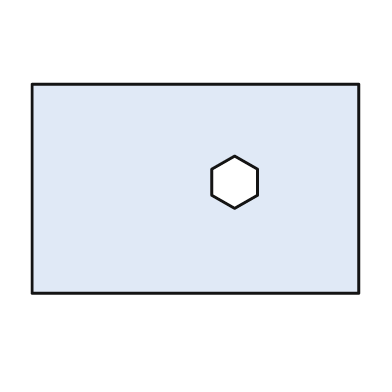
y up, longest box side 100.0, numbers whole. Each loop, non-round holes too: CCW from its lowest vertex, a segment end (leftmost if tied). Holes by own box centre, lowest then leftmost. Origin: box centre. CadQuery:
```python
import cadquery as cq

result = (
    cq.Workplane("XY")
    .moveTo(-50.0, -32.0)
    .lineTo(50.0, -32.0)
    .lineTo(50.0, 32.0)
    .lineTo(-50.0, 32.0)
    .close()
    .moveTo(12.0, -6.0)
    .lineTo(19.0, -2.0)
    .lineTo(19.0, 6.0)
    .lineTo(12.0, 10.0)
    .lineTo(5.0, 6.0)
    .lineTo(5.0, -2.0)
    .close()
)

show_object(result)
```